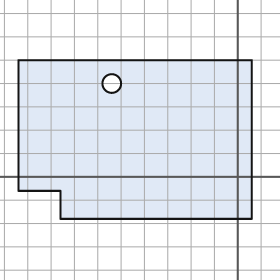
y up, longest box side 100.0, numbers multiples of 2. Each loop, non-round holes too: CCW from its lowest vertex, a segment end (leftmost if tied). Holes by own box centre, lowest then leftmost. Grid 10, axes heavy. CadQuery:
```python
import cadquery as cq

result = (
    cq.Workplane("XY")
    .moveTo(-76.0, -18.0)
    .lineTo(6.0, -18.0)
    .lineTo(6.0, 50.0)
    .lineTo(-94.0, 50.0)
    .lineTo(-94.0, -6.0)
    .lineTo(-76.0, -6.0)
    .close()
    .moveTo(-54.0, 40.0)
    .circle(4.0)
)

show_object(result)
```